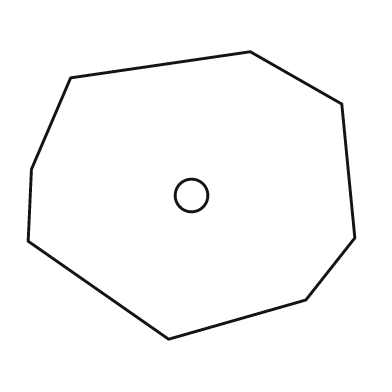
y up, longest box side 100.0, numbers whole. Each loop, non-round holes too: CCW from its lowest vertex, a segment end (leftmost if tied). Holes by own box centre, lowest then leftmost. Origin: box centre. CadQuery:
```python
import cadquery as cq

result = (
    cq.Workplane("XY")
    .moveTo(-7.0, -44.0)
    .lineTo(35.0, -32.0)
    .lineTo(50.0, -13.0)
    .lineTo(46.0, 28.0)
    .lineTo(18.0, 44.0)
    .lineTo(-37.0, 36.0)
    .lineTo(-49.0, 8.0)
    .lineTo(-50.0, -14.0)
    .close()
    .moveTo(0.0, 0.0)
    .circle(5.0)
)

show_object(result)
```